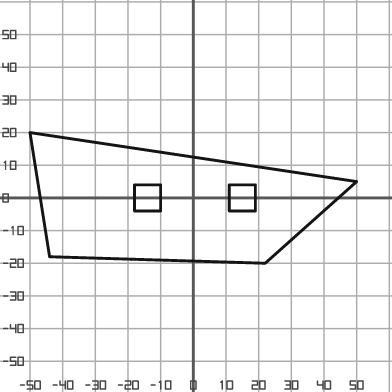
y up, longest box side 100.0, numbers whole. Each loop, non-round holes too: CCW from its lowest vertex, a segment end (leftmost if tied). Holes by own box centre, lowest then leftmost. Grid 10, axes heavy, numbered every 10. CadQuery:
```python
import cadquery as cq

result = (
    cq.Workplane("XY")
    .moveTo(22.0, -20.0)
    .lineTo(50.0, 5.0)
    .lineTo(-50.0, 20.0)
    .lineTo(-44.0, -18.0)
    .close()
    .moveTo(-18.0, -4.0)
    .lineTo(-10.0, -4.0)
    .lineTo(-10.0, 4.0)
    .lineTo(-18.0, 4.0)
    .close()
    .moveTo(11.0, -4.0)
    .lineTo(19.0, -4.0)
    .lineTo(19.0, 4.0)
    .lineTo(11.0, 4.0)
    .close()
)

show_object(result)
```